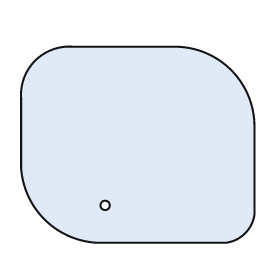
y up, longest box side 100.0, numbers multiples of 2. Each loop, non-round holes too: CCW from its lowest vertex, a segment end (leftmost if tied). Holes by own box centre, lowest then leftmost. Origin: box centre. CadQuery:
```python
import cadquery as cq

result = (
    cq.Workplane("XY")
    .moveTo(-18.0, -42.0)
    .lineTo(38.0, -42.0)
    .threePointArc((46.0, -38.0), (50.0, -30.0))
    .lineTo(50.0, 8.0)
    .threePointArc((40.0, 32.0), (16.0, 42.0))
    .lineTo(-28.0, 42.0)
    .threePointArc((-44.0, 36.0), (-50.0, 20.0))
    .lineTo(-50.0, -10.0)
    .threePointArc((-40.0, -32.0), (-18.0, -42.0))
    .close()
    .moveTo(-14.0, -26.0)
    .circle(2.0)
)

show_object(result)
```